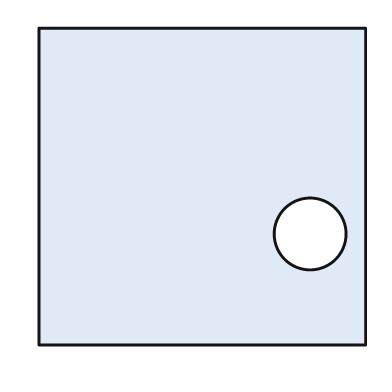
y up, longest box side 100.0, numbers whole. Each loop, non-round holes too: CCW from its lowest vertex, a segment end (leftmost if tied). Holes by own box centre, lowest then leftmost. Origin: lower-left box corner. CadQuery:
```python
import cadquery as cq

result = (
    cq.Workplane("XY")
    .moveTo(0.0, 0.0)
    .lineTo(100.0, 0.0)
    .lineTo(100.0, 97.0)
    .lineTo(0.0, 97.0)
    .close()
    .moveTo(83.0, 34.0)
    .circle(11.0)
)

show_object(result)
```